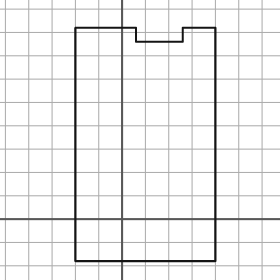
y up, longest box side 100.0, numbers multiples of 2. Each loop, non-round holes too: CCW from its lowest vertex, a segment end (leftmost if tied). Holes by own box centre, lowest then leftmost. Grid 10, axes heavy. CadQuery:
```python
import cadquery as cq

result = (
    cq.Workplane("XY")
    .moveTo(-20.0, -18.0)
    .lineTo(40.0, -18.0)
    .lineTo(40.0, 82.0)
    .lineTo(26.0, 82.0)
    .lineTo(26.0, 76.0)
    .lineTo(6.0, 76.0)
    .lineTo(6.0, 82.0)
    .lineTo(-20.0, 82.0)
    .close()
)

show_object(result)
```